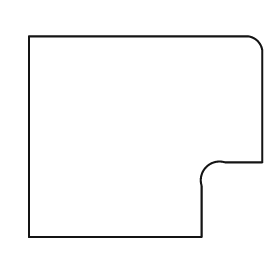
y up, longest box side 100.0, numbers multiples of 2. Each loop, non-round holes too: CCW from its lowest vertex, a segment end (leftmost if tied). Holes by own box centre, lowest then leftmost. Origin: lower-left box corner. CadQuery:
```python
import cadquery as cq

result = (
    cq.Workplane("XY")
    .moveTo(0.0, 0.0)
    .lineTo(74.0, 0.0)
    .lineTo(74.0, 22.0)
    .threePointArc((76.0, 30.0), (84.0, 32.0))
    .lineTo(100.0, 32.0)
    .lineTo(100.0, 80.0)
    .threePointArc((98.0, 84.0), (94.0, 86.0))
    .lineTo(0.0, 86.0)
    .close()
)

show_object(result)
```